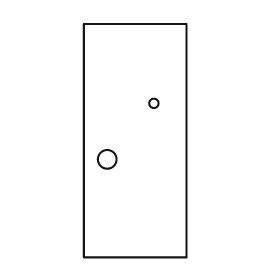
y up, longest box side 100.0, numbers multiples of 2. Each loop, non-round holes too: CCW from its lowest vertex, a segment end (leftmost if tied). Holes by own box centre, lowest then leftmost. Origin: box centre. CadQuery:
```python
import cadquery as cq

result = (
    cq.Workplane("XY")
    .moveTo(-22.0, -50.0)
    .lineTo(22.0, -50.0)
    .lineTo(22.0, 50.0)
    .lineTo(-22.0, 50.0)
    .close()
    .moveTo(-12.0, -8.0)
    .circle(4.0)
    .moveTo(8.0, 16.0)
    .circle(2.0)
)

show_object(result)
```